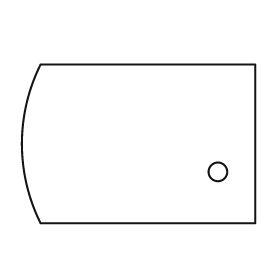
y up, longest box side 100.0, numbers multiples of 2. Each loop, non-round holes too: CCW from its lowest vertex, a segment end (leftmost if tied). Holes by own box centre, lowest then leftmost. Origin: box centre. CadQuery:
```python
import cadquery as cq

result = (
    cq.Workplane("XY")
    .moveTo(-42.0, -34.0)
    .lineTo(50.0, -34.0)
    .lineTo(50.0, 34.0)
    .lineTo(-42.0, 34.0)
    .threePointArc((-50.0, 0.0), (-42.0, -34.0))
    .close()
    .moveTo(34.0, -12.0)
    .circle(4.0)
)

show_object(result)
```